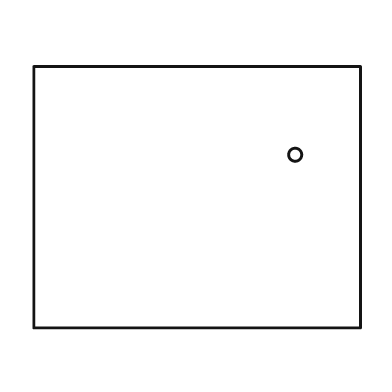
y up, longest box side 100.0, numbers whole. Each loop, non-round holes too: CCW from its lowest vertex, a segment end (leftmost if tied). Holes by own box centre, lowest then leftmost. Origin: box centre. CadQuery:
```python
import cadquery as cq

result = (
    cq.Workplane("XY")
    .moveTo(-50.0, -40.0)
    .lineTo(50.0, -40.0)
    .lineTo(50.0, 40.0)
    .lineTo(-50.0, 40.0)
    .close()
    .moveTo(30.0, 13.0)
    .circle(2.0)
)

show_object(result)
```